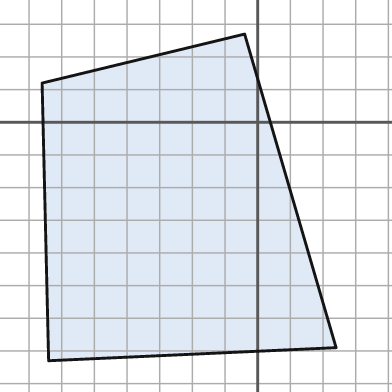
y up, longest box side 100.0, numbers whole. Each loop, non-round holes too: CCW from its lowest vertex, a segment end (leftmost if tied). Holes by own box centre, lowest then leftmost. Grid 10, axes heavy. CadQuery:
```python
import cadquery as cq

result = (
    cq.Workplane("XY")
    .moveTo(-64.0, -73.0)
    .lineTo(24.0, -69.0)
    .lineTo(-4.0, 27.0)
    .lineTo(-66.0, 12.0)
    .close()
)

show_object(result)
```